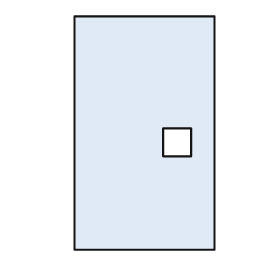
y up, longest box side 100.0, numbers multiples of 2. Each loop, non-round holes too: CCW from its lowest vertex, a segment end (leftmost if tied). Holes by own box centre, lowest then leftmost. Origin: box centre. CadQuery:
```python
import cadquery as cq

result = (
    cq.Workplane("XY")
    .moveTo(-30.0, -50.0)
    .lineTo(30.0, -50.0)
    .lineTo(30.0, 50.0)
    .lineTo(-30.0, 50.0)
    .close()
    .moveTo(8.0, -10.0)
    .lineTo(20.0, -10.0)
    .lineTo(20.0, 2.0)
    .lineTo(8.0, 2.0)
    .close()
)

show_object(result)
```